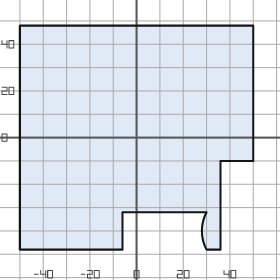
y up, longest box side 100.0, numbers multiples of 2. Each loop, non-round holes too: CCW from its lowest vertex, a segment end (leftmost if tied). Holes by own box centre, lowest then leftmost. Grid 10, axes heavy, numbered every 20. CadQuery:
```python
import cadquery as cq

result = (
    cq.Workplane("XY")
    .moveTo(-50.0, -48.0)
    .lineTo(-6.0, -48.0)
    .lineTo(-6.0, -32.0)
    .lineTo(30.0, -32.0)
    .threePointArc((28.0, -40.0), (30.0, -48.0))
    .lineTo(36.0, -48.0)
    .lineTo(36.0, -10.0)
    .lineTo(50.0, -10.0)
    .lineTo(50.0, 48.0)
    .lineTo(-50.0, 48.0)
    .close()
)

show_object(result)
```